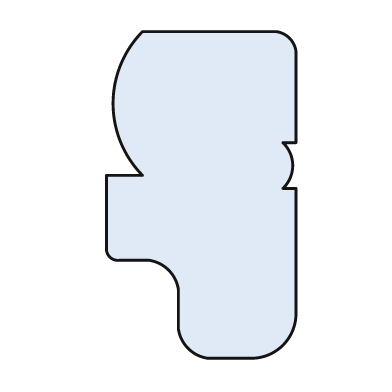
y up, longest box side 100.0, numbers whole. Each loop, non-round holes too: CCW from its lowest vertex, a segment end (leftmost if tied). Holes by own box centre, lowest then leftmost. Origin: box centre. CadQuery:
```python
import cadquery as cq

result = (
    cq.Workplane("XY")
    .moveTo(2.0, -50.0)
    .lineTo(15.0, -50.0)
    .threePointArc((25.0, -46.0), (29.0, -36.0))
    .lineTo(29.0, 2.0)
    .lineTo(25.0, 2.0)
    .threePointArc((28.0, 9.0), (25.0, 16.0))
    .lineTo(29.0, 16.0)
    .lineTo(29.0, 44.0)
    .threePointArc((27.0, 48.0), (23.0, 50.0))
    .lineTo(-18.0, 50.0)
    .threePointArc((-27.0, 28.0), (-18.0, 6.0))
    .lineTo(-29.0, 6.0)
    .lineTo(-29.0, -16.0)
    .threePointArc((-28.0, -19.0), (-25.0, -20.0))
    .lineTo(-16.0, -20.0)
    .threePointArc((-10.0, -23.0), (-7.0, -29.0))
    .lineTo(-7.0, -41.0)
    .threePointArc((-4.0, -47.0), (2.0, -50.0))
    .close()
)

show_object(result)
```